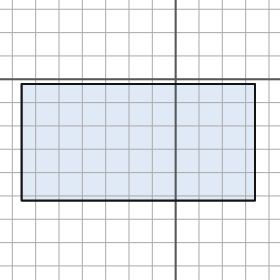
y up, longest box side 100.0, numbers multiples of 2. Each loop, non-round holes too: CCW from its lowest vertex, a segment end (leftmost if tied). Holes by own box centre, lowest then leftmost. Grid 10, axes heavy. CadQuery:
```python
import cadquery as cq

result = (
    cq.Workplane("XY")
    .moveTo(-66.0, -52.0)
    .lineTo(34.0, -52.0)
    .lineTo(34.0, -2.0)
    .lineTo(-66.0, -2.0)
    .close()
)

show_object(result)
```